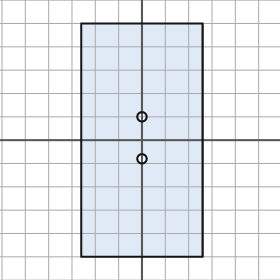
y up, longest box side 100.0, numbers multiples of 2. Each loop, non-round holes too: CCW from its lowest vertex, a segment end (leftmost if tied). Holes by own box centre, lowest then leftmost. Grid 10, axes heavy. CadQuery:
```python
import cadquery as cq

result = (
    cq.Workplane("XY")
    .moveTo(-26.0, -50.0)
    .lineTo(26.0, -50.0)
    .lineTo(26.0, 50.0)
    .lineTo(-26.0, 50.0)
    .close()
    .moveTo(0.0, -8.0)
    .circle(2.0)
    .moveTo(0.0, 10.0)
    .circle(2.0)
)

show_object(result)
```